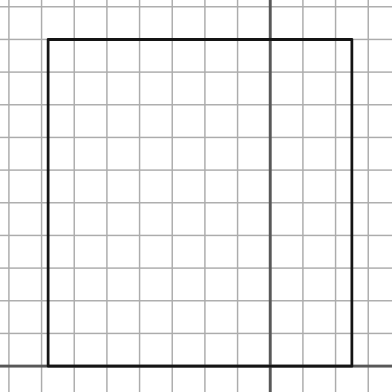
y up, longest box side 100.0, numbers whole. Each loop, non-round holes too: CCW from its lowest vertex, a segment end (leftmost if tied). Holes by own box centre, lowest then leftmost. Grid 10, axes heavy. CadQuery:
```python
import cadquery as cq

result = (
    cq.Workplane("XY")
    .moveTo(-68.0, 0.0)
    .lineTo(25.0, 0.0)
    .lineTo(25.0, 100.0)
    .lineTo(-68.0, 100.0)
    .close()
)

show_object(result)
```